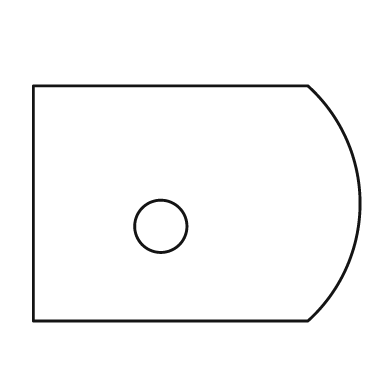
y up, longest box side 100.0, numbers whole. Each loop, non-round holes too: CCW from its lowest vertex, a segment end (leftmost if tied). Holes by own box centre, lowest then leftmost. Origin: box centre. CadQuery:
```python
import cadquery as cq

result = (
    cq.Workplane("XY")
    .moveTo(-50.0, -36.0)
    .lineTo(34.0, -36.0)
    .threePointArc((50.0, 0.0), (34.0, 36.0))
    .lineTo(-50.0, 36.0)
    .close()
    .moveTo(-11.0, -7.0)
    .circle(8.0)
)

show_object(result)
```